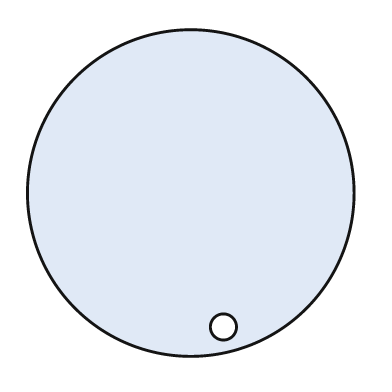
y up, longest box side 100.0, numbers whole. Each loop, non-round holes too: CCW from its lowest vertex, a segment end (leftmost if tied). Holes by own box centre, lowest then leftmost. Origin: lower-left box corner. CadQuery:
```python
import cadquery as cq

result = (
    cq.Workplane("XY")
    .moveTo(50.0, 50.0)
    .circle(50.0)
    .moveTo(60.0, 9.0)
    .circle(4.0)
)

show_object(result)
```